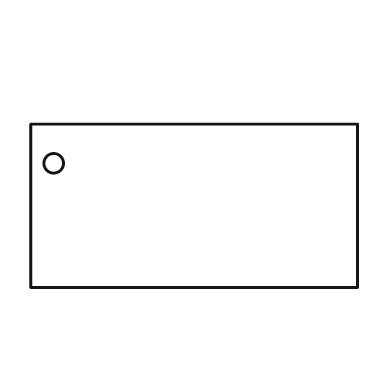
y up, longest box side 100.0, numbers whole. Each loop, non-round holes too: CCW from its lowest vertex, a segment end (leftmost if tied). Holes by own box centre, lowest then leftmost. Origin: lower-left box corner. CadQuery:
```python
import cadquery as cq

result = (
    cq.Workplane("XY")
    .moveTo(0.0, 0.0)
    .lineTo(100.0, 0.0)
    .lineTo(100.0, 50.0)
    .lineTo(0.0, 50.0)
    .close()
    .moveTo(7.0, 38.0)
    .circle(3.0)
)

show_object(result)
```